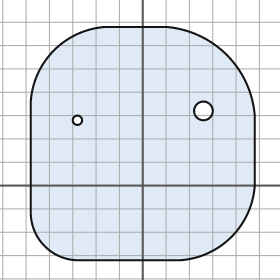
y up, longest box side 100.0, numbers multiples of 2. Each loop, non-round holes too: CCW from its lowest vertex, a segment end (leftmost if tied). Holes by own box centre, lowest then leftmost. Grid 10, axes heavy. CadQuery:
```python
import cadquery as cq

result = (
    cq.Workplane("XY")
    .moveTo(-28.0, -32.0)
    .lineTo(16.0, -32.0)
    .threePointArc((38.0, -22.0), (48.0, 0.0))
    .lineTo(48.0, 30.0)
    .threePointArc((36.0, 56.0), (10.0, 68.0))
    .lineTo(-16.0, 68.0)
    .threePointArc((-38.0, 58.0), (-48.0, 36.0))
    .lineTo(-48.0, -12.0)
    .threePointArc((-42.0, -26.0), (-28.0, -32.0))
    .close()
    .moveTo(-28.0, 28.0)
    .circle(2.0)
    .moveTo(26.0, 32.0)
    .circle(4.0)
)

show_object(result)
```